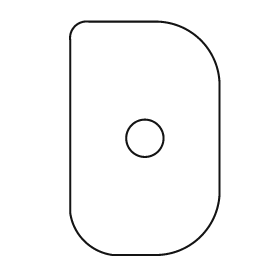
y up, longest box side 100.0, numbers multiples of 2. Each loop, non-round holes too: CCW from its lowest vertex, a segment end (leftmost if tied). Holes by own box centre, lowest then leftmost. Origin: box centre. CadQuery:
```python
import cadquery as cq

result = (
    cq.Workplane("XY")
    .moveTo(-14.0, -50.0)
    .lineTo(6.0, -50.0)
    .threePointArc((24.0, -42.0), (32.0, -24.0))
    .lineTo(32.0, 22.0)
    .threePointArc((24.0, 42.0), (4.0, 50.0))
    .lineTo(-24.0, 50.0)
    .threePointArc((-30.0, 48.0), (-32.0, 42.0))
    .lineTo(-32.0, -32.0)
    .threePointArc((-26.0, -44.0), (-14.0, -50.0))
    .close()
    .moveTo(0.0, 0.0)
    .circle(8.0)
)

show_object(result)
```